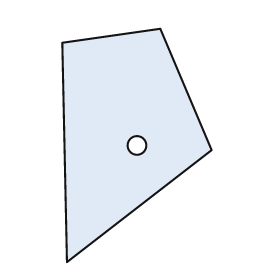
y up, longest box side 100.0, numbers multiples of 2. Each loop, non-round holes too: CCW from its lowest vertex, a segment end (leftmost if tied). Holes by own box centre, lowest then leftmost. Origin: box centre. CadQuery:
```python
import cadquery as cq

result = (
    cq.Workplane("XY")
    .moveTo(-30.0, -50.0)
    .lineTo(32.0, -2.0)
    .lineTo(10.0, 50.0)
    .lineTo(-32.0, 44.0)
    .close()
    .moveTo(0.0, 0.0)
    .circle(4.0)
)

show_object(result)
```